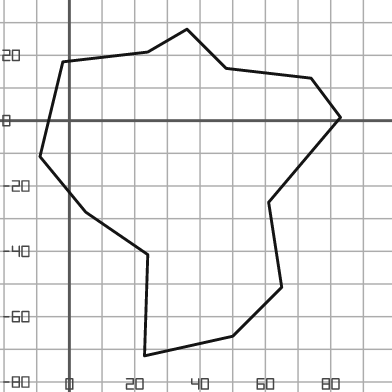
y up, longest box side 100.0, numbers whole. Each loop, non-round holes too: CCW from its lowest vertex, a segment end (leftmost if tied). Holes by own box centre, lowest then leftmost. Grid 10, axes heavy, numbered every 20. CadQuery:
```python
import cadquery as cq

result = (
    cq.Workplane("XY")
    .moveTo(23.0, -72.0)
    .lineTo(50.0, -66.0)
    .lineTo(65.0, -51.0)
    .lineTo(61.0, -25.0)
    .lineTo(83.0, 1.0)
    .lineTo(74.0, 13.0)
    .lineTo(48.0, 16.0)
    .lineTo(36.0, 28.0)
    .lineTo(24.0, 21.0)
    .lineTo(-2.0, 18.0)
    .lineTo(-9.0, -11.0)
    .lineTo(5.0, -28.0)
    .lineTo(24.0, -41.0)
    .close()
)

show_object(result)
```